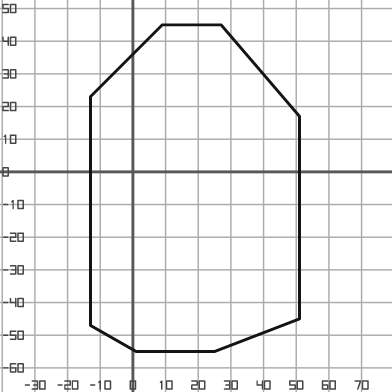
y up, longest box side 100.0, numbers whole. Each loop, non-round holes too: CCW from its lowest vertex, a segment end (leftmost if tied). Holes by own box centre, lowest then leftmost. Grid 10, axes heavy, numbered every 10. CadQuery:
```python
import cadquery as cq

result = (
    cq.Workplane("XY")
    .moveTo(1.0, -55.0)
    .lineTo(25.0, -55.0)
    .lineTo(51.0, -45.0)
    .lineTo(51.0, 17.0)
    .lineTo(27.0, 45.0)
    .lineTo(9.0, 45.0)
    .lineTo(-13.0, 23.0)
    .lineTo(-13.0, -47.0)
    .close()
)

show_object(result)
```